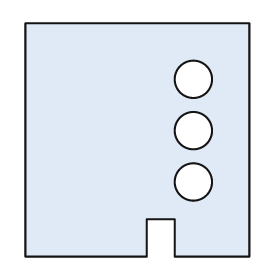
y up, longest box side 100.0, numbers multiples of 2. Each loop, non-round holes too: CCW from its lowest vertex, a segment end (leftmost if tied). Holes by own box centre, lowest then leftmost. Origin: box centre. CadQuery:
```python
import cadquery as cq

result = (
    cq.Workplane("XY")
    .moveTo(-48.0, -50.0)
    .lineTo(4.0, -50.0)
    .lineTo(4.0, -34.0)
    .lineTo(16.0, -34.0)
    .lineTo(16.0, -50.0)
    .lineTo(48.0, -50.0)
    .lineTo(48.0, 50.0)
    .lineTo(-48.0, 50.0)
    .close()
    .moveTo(24.0, -18.0)
    .circle(8.0)
    .moveTo(24.0, 4.0)
    .circle(8.0)
    .moveTo(24.0, 26.0)
    .circle(8.0)
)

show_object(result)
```